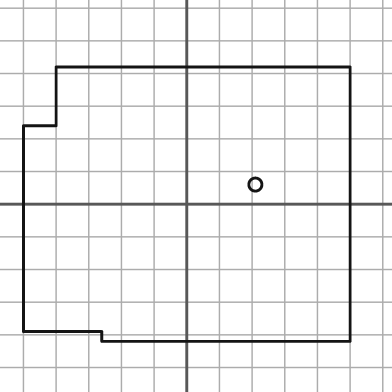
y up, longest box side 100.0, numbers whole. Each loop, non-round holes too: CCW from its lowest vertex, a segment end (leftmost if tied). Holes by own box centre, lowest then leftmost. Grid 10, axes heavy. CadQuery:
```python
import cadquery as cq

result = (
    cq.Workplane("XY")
    .moveTo(-26.0, -42.0)
    .lineTo(50.0, -42.0)
    .lineTo(50.0, 42.0)
    .lineTo(-40.0, 42.0)
    .lineTo(-40.0, 24.0)
    .lineTo(-50.0, 24.0)
    .lineTo(-50.0, -39.0)
    .lineTo(-26.0, -39.0)
    .close()
    .moveTo(21.0, 6.0)
    .circle(2.0)
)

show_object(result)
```